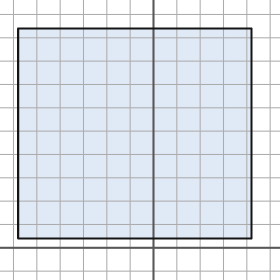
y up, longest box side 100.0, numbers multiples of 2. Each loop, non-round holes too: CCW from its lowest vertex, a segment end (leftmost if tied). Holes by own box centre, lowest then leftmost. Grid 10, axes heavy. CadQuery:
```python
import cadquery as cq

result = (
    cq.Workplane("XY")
    .moveTo(-58.0, 4.0)
    .lineTo(42.0, 4.0)
    .lineTo(42.0, 94.0)
    .lineTo(-58.0, 94.0)
    .close()
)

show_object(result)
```